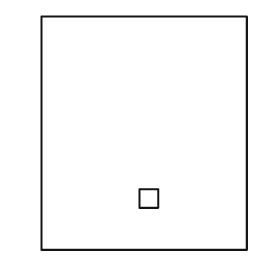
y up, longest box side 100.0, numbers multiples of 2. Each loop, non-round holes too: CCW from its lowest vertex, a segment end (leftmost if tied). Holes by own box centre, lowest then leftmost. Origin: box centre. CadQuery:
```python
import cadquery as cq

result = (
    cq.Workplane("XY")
    .moveTo(-44.0, -50.0)
    .lineTo(44.0, -50.0)
    .lineTo(44.0, 50.0)
    .lineTo(-44.0, 50.0)
    .close()
    .moveTo(-2.0, -32.0)
    .lineTo(6.0, -32.0)
    .lineTo(6.0, -24.0)
    .lineTo(-2.0, -24.0)
    .close()
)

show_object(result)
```